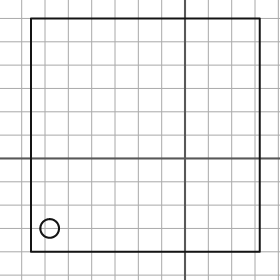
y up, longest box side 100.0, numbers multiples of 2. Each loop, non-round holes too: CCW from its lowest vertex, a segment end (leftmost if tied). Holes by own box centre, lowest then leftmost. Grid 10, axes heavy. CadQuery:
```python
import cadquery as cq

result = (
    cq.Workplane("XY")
    .moveTo(-66.0, -40.0)
    .lineTo(32.0, -40.0)
    .lineTo(32.0, 60.0)
    .lineTo(-66.0, 60.0)
    .close()
    .moveTo(-58.0, -30.0)
    .circle(4.0)
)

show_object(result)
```